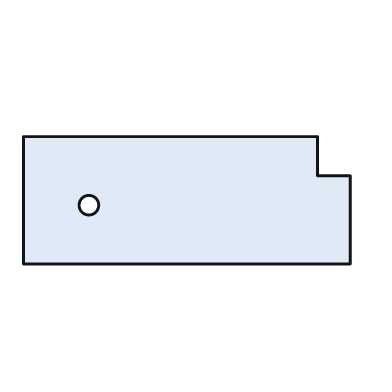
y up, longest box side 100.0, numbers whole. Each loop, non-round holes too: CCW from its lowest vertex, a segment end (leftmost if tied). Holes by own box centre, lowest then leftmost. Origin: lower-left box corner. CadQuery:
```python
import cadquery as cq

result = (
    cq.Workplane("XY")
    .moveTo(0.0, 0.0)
    .lineTo(100.0, 0.0)
    .lineTo(100.0, 27.0)
    .lineTo(90.0, 27.0)
    .lineTo(90.0, 39.0)
    .lineTo(0.0, 39.0)
    .close()
    .moveTo(20.0, 18.0)
    .circle(3.0)
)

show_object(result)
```